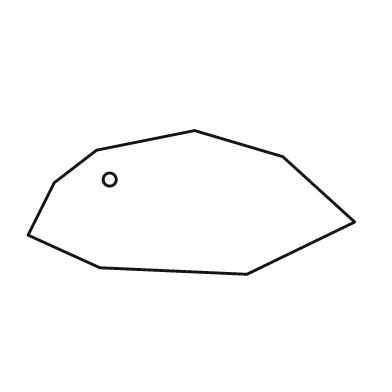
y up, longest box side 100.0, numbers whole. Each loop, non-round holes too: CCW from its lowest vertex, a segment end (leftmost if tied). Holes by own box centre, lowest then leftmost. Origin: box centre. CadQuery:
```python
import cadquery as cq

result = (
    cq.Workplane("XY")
    .moveTo(17.0, -22.0)
    .lineTo(50.0, -6.0)
    .lineTo(28.0, 14.0)
    .lineTo(1.0, 22.0)
    .lineTo(-29.0, 16.0)
    .lineTo(-42.0, 6.0)
    .lineTo(-50.0, -10.0)
    .lineTo(-28.0, -20.0)
    .close()
    .moveTo(-25.0, 7.0)
    .circle(2.0)
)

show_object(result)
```